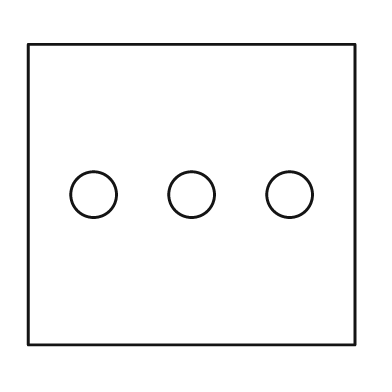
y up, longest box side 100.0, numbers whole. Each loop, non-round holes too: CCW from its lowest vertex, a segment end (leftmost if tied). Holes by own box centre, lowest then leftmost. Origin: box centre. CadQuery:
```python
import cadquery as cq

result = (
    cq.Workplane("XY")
    .moveTo(-50.0, -46.0)
    .lineTo(50.0, -46.0)
    .lineTo(50.0, 46.0)
    .lineTo(-50.0, 46.0)
    .close()
    .moveTo(-30.0, 0.0)
    .circle(7.0)
    .moveTo(0.0, 0.0)
    .circle(7.0)
    .moveTo(30.0, 0.0)
    .circle(7.0)
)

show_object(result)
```